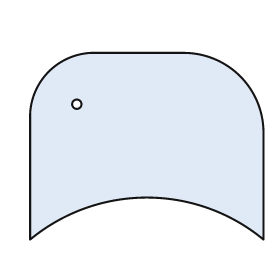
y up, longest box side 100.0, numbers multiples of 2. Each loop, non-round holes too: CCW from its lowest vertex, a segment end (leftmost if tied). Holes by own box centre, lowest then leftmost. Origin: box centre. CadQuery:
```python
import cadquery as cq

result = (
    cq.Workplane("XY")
    .moveTo(-50.0, -40.0)
    .threePointArc((0.0, -22.0), (50.0, -40.0))
    .lineTo(50.0, 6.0)
    .threePointArc((40.0, 30.0), (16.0, 40.0))
    .lineTo(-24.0, 40.0)
    .threePointArc((-42.0, 32.0), (-50.0, 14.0))
    .close()
    .moveTo(-30.0, 18.0)
    .circle(2.0)
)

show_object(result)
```